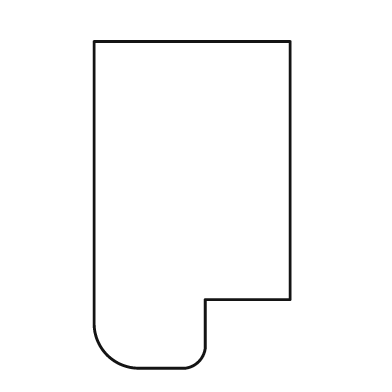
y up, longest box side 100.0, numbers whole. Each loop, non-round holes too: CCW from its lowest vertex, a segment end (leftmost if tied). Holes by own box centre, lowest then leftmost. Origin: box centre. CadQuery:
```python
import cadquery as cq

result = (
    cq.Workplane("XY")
    .moveTo(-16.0, -50.0)
    .lineTo(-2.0, -50.0)
    .threePointArc((2.0, -48.0), (4.0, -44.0))
    .lineTo(4.0, -29.0)
    .lineTo(30.0, -29.0)
    .lineTo(30.0, 50.0)
    .lineTo(-30.0, 50.0)
    .lineTo(-30.0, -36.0)
    .threePointArc((-26.0, -46.0), (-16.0, -50.0))
    .close()
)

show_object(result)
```